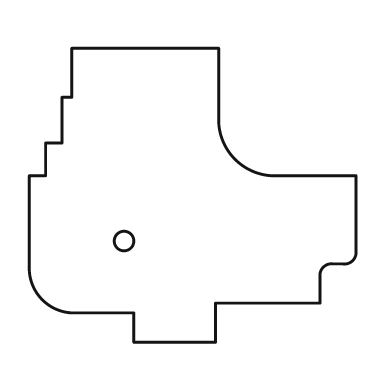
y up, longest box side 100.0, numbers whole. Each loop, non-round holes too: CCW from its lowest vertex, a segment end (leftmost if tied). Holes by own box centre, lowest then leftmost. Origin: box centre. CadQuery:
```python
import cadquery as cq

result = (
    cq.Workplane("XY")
    .moveTo(-18.0, -45.0)
    .lineTo(7.0, -45.0)
    .lineTo(7.0, -33.0)
    .lineTo(39.0, -33.0)
    .lineTo(39.0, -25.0)
    .threePointArc((40.0, -22.0), (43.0, -21.0))
    .lineTo(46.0, -21.0)
    .threePointArc((49.0, -20.0), (50.0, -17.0))
    .lineTo(50.0, 6.0)
    .lineTo(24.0, 6.0)
    .threePointArc((13.0, 11.0), (8.0, 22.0))
    .lineTo(8.0, 45.0)
    .lineTo(-37.0, 45.0)
    .lineTo(-37.0, 30.0)
    .lineTo(-40.0, 30.0)
    .lineTo(-40.0, 16.0)
    .lineTo(-45.0, 16.0)
    .lineTo(-45.0, 6.0)
    .lineTo(-50.0, 6.0)
    .lineTo(-50.0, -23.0)
    .threePointArc((-46.0, -32.0), (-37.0, -36.0))
    .lineTo(-18.0, -36.0)
    .close()
    .moveTo(-21.0, -14.0)
    .circle(3.0)
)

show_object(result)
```